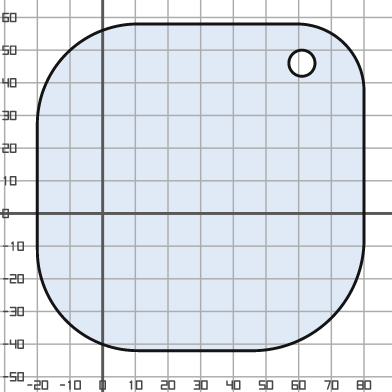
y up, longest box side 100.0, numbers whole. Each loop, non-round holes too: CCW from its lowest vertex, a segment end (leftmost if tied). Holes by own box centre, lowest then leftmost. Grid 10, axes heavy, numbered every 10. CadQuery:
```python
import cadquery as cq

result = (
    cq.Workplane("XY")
    .moveTo(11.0, -42.0)
    .lineTo(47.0, -42.0)
    .threePointArc((70.0, -32.0), (80.0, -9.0))
    .lineTo(80.0, 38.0)
    .threePointArc((74.0, 52.0), (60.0, 58.0))
    .lineTo(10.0, 58.0)
    .threePointArc((-11.0, 49.0), (-20.0, 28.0))
    .lineTo(-20.0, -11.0)
    .threePointArc((-11.0, -33.0), (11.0, -42.0))
    .close()
    .moveTo(61.0, 46.0)
    .circle(4.0)
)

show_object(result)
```